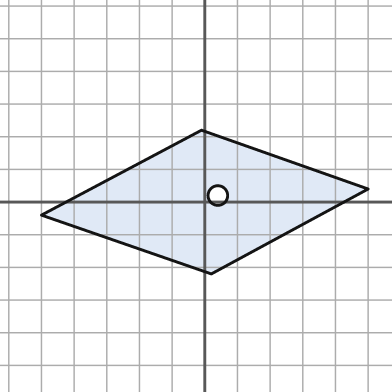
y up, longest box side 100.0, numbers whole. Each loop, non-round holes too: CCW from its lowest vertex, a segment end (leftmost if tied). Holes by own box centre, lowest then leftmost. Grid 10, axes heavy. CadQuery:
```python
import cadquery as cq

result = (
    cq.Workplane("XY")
    .moveTo(2.0, -22.0)
    .lineTo(50.0, 4.0)
    .lineTo(-1.0, 22.0)
    .lineTo(-50.0, -4.0)
    .close()
    .moveTo(4.0, 2.0)
    .circle(3.0)
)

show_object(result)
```